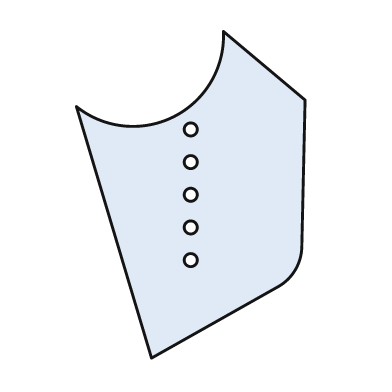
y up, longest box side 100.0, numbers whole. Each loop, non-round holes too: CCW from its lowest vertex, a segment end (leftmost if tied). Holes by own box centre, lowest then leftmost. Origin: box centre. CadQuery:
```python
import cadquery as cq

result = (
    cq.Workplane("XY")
    .moveTo(-12.0, -50.0)
    .lineTo(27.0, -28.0)
    .threePointArc((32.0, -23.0), (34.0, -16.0))
    .lineTo(35.0, 29.0)
    .lineTo(10.0, 50.0)
    .threePointArc((-5.0, 24.0), (-35.0, 27.0))
    .close()
    .moveTo(0.0, -20.0)
    .circle(2.0)
    .moveTo(0.0, -10.0)
    .circle(2.0)
    .moveTo(0.0, 0.0)
    .circle(2.0)
    .moveTo(0.0, 10.0)
    .circle(2.0)
    .moveTo(0.0, 20.0)
    .circle(2.0)
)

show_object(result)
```